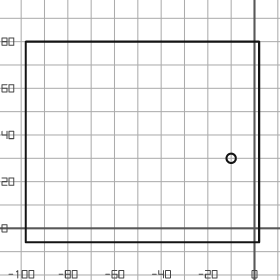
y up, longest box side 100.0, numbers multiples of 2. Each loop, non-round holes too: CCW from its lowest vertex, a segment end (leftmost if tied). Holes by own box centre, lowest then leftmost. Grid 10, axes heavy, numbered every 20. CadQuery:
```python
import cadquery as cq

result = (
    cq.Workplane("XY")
    .moveTo(-98.0, -6.0)
    .lineTo(2.0, -6.0)
    .lineTo(2.0, 80.0)
    .lineTo(-98.0, 80.0)
    .close()
    .moveTo(-10.0, 30.0)
    .circle(2.0)
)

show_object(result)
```